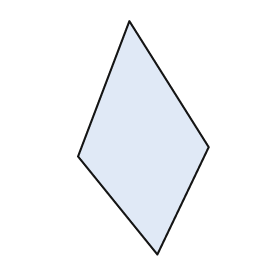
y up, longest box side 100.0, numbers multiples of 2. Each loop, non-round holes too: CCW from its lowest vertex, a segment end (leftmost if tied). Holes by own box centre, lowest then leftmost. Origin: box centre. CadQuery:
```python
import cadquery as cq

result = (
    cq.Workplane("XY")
    .moveTo(6.0, -50.0)
    .lineTo(28.0, -4.0)
    .lineTo(-6.0, 50.0)
    .lineTo(-28.0, -8.0)
    .close()
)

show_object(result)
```